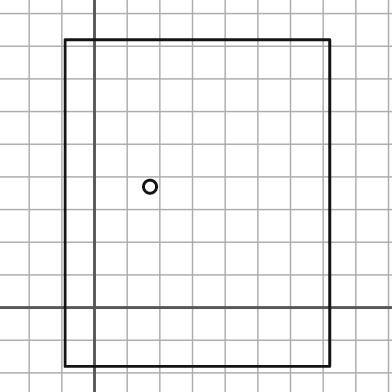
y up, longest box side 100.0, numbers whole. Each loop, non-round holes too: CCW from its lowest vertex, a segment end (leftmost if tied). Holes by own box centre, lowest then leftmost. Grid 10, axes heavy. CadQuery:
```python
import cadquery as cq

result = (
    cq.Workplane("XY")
    .moveTo(-9.0, -18.0)
    .lineTo(72.0, -18.0)
    .lineTo(72.0, 82.0)
    .lineTo(-9.0, 82.0)
    .close()
    .moveTo(17.0, 37.0)
    .circle(2.0)
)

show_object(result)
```